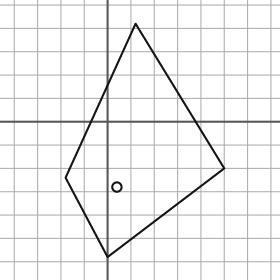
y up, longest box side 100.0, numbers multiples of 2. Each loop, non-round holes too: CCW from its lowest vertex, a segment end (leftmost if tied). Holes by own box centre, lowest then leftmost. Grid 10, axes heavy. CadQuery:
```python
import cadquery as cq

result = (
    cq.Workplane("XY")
    .moveTo(0.0, -58.0)
    .lineTo(50.0, -20.0)
    .lineTo(12.0, 42.0)
    .lineTo(-18.0, -24.0)
    .close()
    .moveTo(4.0, -28.0)
    .circle(2.0)
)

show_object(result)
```